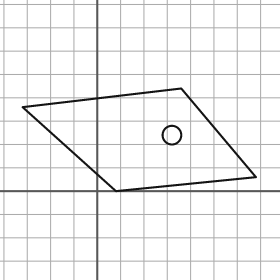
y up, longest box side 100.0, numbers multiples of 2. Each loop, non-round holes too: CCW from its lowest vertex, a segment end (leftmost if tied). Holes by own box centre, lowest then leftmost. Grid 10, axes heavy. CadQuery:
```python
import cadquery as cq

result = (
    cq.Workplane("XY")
    .moveTo(8.0, 0.0)
    .lineTo(68.0, 6.0)
    .lineTo(36.0, 44.0)
    .lineTo(-32.0, 36.0)
    .close()
    .moveTo(32.0, 24.0)
    .circle(4.0)
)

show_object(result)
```